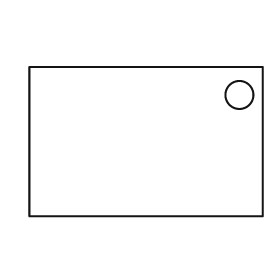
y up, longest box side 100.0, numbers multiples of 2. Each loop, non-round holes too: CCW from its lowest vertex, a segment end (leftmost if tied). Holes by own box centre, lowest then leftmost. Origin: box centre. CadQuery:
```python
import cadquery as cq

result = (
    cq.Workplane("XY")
    .moveTo(-50.0, -32.0)
    .lineTo(50.0, -32.0)
    .lineTo(50.0, 32.0)
    .lineTo(-50.0, 32.0)
    .close()
    .moveTo(40.0, 20.0)
    .circle(6.0)
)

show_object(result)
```